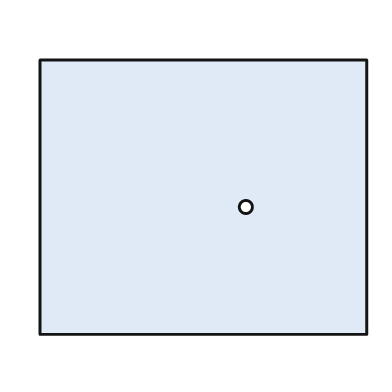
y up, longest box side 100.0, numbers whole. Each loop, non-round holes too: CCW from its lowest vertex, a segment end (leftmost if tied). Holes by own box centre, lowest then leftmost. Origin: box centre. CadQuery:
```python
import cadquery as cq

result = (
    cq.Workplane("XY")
    .moveTo(-50.0, -42.0)
    .lineTo(50.0, -42.0)
    .lineTo(50.0, 42.0)
    .lineTo(-50.0, 42.0)
    .close()
    .moveTo(13.0, -3.0)
    .circle(2.0)
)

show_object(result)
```